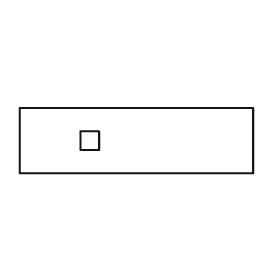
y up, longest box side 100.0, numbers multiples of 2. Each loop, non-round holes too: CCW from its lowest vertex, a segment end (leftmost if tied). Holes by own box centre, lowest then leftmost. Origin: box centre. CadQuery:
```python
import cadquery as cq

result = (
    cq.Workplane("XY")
    .moveTo(-50.0, -14.0)
    .lineTo(50.0, -14.0)
    .lineTo(50.0, 14.0)
    .lineTo(-50.0, 14.0)
    .close()
    .moveTo(-24.0, -4.0)
    .lineTo(-16.0, -4.0)
    .lineTo(-16.0, 4.0)
    .lineTo(-24.0, 4.0)
    .close()
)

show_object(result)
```